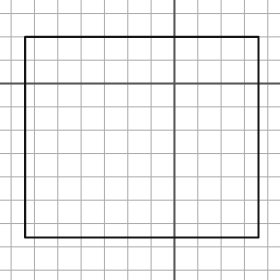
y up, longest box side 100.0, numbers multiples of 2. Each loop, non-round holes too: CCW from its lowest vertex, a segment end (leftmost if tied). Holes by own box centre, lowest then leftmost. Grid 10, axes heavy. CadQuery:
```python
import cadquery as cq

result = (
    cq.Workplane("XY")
    .moveTo(-64.0, -66.0)
    .lineTo(36.0, -66.0)
    .lineTo(36.0, 20.0)
    .lineTo(-64.0, 20.0)
    .close()
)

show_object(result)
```